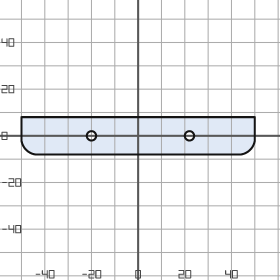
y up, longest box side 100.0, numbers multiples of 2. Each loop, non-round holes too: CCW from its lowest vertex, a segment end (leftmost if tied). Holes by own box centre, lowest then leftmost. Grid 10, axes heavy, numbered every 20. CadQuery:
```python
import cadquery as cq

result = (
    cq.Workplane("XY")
    .moveTo(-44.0, -8.0)
    .lineTo(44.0, -8.0)
    .threePointArc((48.0, -6.0), (50.0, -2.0))
    .lineTo(50.0, 8.0)
    .lineTo(-50.0, 8.0)
    .lineTo(-50.0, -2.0)
    .threePointArc((-48.0, -6.0), (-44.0, -8.0))
    .close()
    .moveTo(-20.0, 0.0)
    .circle(2.0)
    .moveTo(22.0, 0.0)
    .circle(2.0)
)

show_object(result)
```